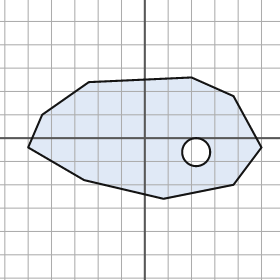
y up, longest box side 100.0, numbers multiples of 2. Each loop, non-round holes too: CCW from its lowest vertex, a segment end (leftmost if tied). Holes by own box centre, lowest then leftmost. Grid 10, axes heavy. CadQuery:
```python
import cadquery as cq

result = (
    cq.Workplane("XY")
    .moveTo(8.0, -26.0)
    .lineTo(38.0, -20.0)
    .lineTo(50.0, -4.0)
    .lineTo(38.0, 18.0)
    .lineTo(20.0, 26.0)
    .lineTo(-24.0, 24.0)
    .lineTo(-44.0, 10.0)
    .lineTo(-50.0, -4.0)
    .lineTo(-26.0, -18.0)
    .close()
    .moveTo(22.0, -6.0)
    .circle(6.0)
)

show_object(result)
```